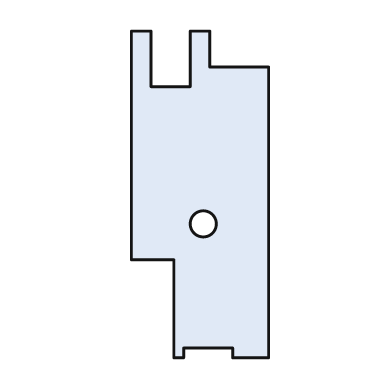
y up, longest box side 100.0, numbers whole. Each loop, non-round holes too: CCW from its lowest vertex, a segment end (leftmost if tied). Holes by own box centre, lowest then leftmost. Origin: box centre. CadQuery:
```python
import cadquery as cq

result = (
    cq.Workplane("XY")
    .moveTo(-8.0, -50.0)
    .lineTo(-5.0, -50.0)
    .lineTo(-5.0, -47.0)
    .lineTo(10.0, -47.0)
    .lineTo(10.0, -50.0)
    .lineTo(21.0, -50.0)
    .lineTo(21.0, 39.0)
    .lineTo(3.0, 39.0)
    .lineTo(3.0, 50.0)
    .lineTo(-3.0, 50.0)
    .lineTo(-3.0, 33.0)
    .lineTo(-15.0, 33.0)
    .lineTo(-15.0, 50.0)
    .lineTo(-21.0, 50.0)
    .lineTo(-21.0, -20.0)
    .lineTo(-8.0, -20.0)
    .close()
    .moveTo(1.0, -9.0)
    .circle(4.0)
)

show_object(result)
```